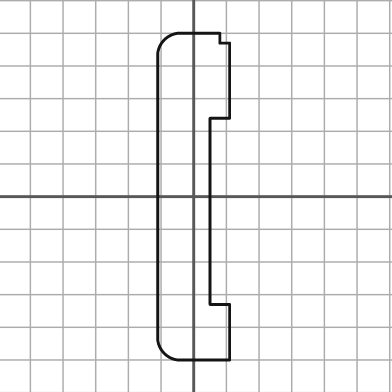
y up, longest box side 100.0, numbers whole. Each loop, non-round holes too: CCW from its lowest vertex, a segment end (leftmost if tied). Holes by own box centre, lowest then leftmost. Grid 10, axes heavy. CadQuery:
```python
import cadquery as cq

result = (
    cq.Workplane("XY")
    .moveTo(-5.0, -50.0)
    .lineTo(11.0, -50.0)
    .lineTo(11.0, -33.0)
    .lineTo(5.0, -33.0)
    .lineTo(5.0, 24.0)
    .lineTo(11.0, 24.0)
    .lineTo(11.0, 47.0)
    .lineTo(8.0, 47.0)
    .lineTo(8.0, 50.0)
    .lineTo(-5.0, 50.0)
    .threePointArc((-9.0, 48.0), (-11.0, 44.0))
    .lineTo(-11.0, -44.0)
    .threePointArc((-9.0, -48.0), (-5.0, -50.0))
    .close()
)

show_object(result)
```